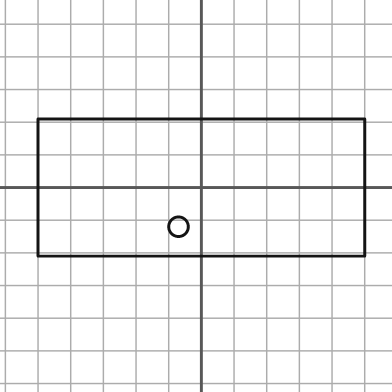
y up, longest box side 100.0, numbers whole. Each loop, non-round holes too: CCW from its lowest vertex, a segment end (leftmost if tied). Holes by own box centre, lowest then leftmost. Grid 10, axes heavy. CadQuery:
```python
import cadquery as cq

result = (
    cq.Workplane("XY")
    .moveTo(-50.0, -21.0)
    .lineTo(50.0, -21.0)
    .lineTo(50.0, 21.0)
    .lineTo(-50.0, 21.0)
    .close()
    .moveTo(-7.0, -12.0)
    .circle(3.0)
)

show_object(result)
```